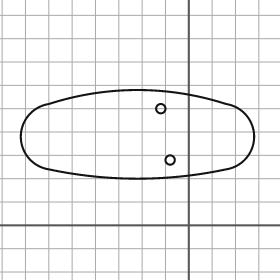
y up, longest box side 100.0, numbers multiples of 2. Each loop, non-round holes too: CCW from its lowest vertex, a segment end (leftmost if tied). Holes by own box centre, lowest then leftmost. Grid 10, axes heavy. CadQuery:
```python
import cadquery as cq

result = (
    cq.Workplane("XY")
    .moveTo(-60.0, 24.0)
    .threePointArc((-22.0, 20.0), (16.0, 24.0))
    .threePointArc((28.0, 38.0), (16.0, 52.0))
    .threePointArc((-22.0, 58.0), (-60.0, 52.0))
    .threePointArc((-72.0, 38.0), (-60.0, 24.0))
    .close()
    .moveTo(-8.0, 28.0)
    .circle(2.0)
    .moveTo(-12.0, 50.0)
    .circle(2.0)
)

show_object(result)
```